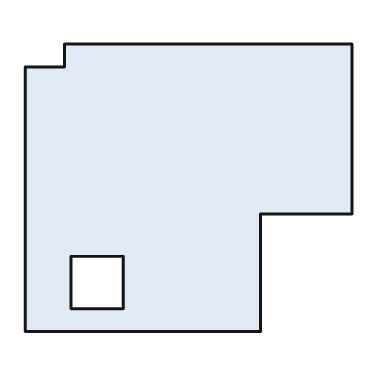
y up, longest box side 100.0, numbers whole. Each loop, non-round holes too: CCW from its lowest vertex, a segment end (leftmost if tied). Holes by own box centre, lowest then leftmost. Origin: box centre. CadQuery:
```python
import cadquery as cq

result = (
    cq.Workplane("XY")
    .moveTo(-50.0, -44.0)
    .lineTo(22.0, -44.0)
    .lineTo(22.0, -8.0)
    .lineTo(50.0, -8.0)
    .lineTo(50.0, 44.0)
    .lineTo(-38.0, 44.0)
    .lineTo(-38.0, 37.0)
    .lineTo(-50.0, 37.0)
    .close()
    .moveTo(-36.0, -37.0)
    .lineTo(-20.0, -37.0)
    .lineTo(-20.0, -21.0)
    .lineTo(-36.0, -21.0)
    .close()
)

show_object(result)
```